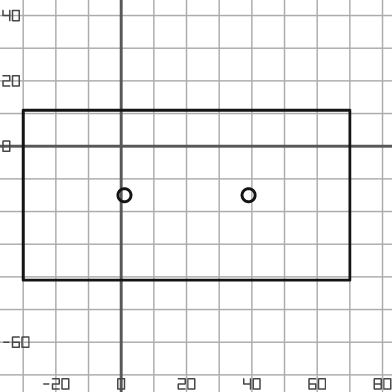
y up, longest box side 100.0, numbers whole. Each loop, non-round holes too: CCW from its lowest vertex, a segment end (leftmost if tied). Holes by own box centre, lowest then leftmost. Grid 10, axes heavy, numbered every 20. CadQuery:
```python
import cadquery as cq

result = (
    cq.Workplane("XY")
    .moveTo(-30.0, -41.0)
    .lineTo(70.0, -41.0)
    .lineTo(70.0, 11.0)
    .lineTo(-30.0, 11.0)
    .close()
    .moveTo(1.0, -15.0)
    .circle(2.0)
    .moveTo(39.0, -15.0)
    .circle(2.0)
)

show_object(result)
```